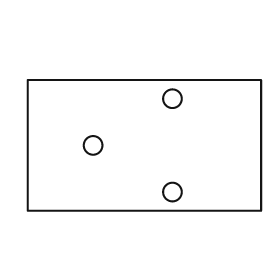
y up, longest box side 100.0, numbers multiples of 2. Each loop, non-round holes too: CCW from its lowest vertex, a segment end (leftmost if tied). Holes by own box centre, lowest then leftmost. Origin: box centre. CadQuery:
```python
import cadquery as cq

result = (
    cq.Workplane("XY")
    .moveTo(-50.0, -28.0)
    .lineTo(50.0, -28.0)
    .lineTo(50.0, 28.0)
    .lineTo(-50.0, 28.0)
    .close()
    .moveTo(12.0, -20.0)
    .circle(4.0)
    .moveTo(-22.0, 0.0)
    .circle(4.0)
    .moveTo(12.0, 20.0)
    .circle(4.0)
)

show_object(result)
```